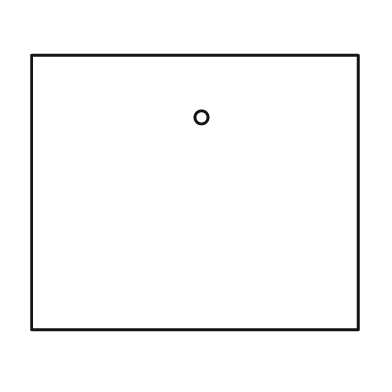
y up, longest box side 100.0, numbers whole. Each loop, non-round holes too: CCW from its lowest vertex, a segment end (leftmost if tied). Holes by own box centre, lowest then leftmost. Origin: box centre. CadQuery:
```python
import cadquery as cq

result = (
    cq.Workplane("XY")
    .moveTo(-50.0, -42.0)
    .lineTo(50.0, -42.0)
    .lineTo(50.0, 42.0)
    .lineTo(-50.0, 42.0)
    .close()
    .moveTo(2.0, 23.0)
    .circle(2.0)
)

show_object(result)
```